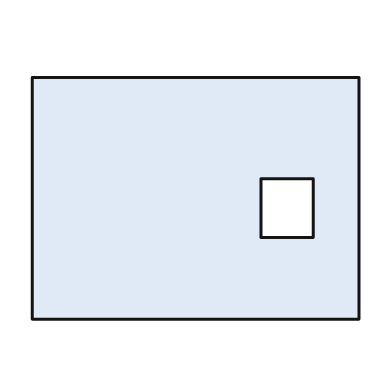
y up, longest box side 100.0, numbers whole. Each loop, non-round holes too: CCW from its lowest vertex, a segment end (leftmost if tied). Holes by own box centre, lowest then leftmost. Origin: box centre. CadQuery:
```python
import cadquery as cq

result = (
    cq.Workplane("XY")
    .moveTo(-50.0, -37.0)
    .lineTo(50.0, -37.0)
    .lineTo(50.0, 37.0)
    .lineTo(-50.0, 37.0)
    .close()
    .moveTo(20.0, -12.0)
    .lineTo(36.0, -12.0)
    .lineTo(36.0, 6.0)
    .lineTo(20.0, 6.0)
    .close()
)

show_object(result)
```